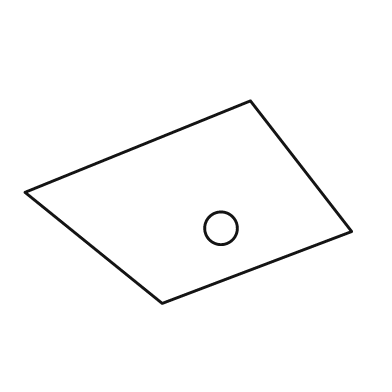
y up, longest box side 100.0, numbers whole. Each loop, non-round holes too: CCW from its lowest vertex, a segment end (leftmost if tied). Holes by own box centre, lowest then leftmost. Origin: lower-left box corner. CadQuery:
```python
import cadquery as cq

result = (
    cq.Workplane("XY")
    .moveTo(42.0, 0.0)
    .lineTo(100.0, 22.0)
    .lineTo(69.0, 62.0)
    .lineTo(0.0, 34.0)
    .close()
    .moveTo(60.0, 23.0)
    .circle(5.0)
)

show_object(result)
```